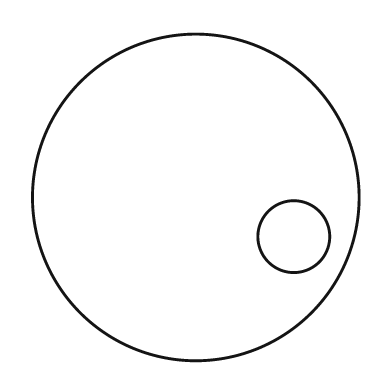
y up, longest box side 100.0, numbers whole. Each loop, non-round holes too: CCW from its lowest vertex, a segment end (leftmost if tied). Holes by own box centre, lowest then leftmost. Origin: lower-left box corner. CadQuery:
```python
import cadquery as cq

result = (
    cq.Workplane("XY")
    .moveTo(50.0, 50.0)
    .circle(50.0)
    .moveTo(80.0, 38.0)
    .circle(11.0)
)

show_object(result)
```